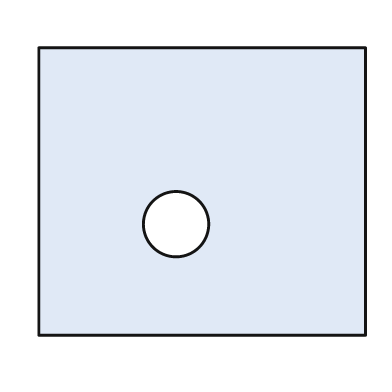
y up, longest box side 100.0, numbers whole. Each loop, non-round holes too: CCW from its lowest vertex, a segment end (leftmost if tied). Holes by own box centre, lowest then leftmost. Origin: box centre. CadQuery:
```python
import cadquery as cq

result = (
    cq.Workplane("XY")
    .moveTo(-50.0, -44.0)
    .lineTo(50.0, -44.0)
    .lineTo(50.0, 44.0)
    .lineTo(-50.0, 44.0)
    .close()
    .moveTo(-8.0, -10.0)
    .circle(10.0)
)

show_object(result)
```